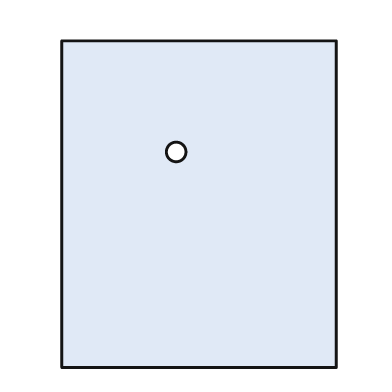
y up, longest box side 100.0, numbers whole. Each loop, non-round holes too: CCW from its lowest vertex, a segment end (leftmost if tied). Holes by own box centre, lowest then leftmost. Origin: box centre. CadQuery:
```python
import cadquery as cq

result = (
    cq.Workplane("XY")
    .moveTo(-42.0, -50.0)
    .lineTo(42.0, -50.0)
    .lineTo(42.0, 50.0)
    .lineTo(-42.0, 50.0)
    .close()
    .moveTo(-7.0, 16.0)
    .circle(3.0)
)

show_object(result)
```